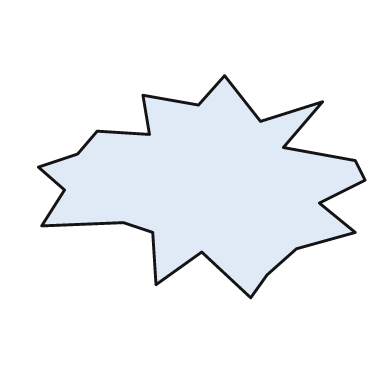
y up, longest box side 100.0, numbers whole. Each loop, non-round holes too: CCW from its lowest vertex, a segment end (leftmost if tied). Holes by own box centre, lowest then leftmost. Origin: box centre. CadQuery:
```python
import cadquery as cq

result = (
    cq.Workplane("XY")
    .moveTo(15.0, -34.0)
    .lineTo(20.0, -27.0)
    .lineTo(29.0, -19.0)
    .lineTo(47.0, -14.0)
    .lineTo(36.0, -5.0)
    .lineTo(50.0, 2.0)
    .lineTo(47.0, 8.0)
    .lineTo(25.0, 12.0)
    .lineTo(37.0, 26.0)
    .lineTo(18.0, 20.0)
    .lineTo(7.0, 34.0)
    .lineTo(-1.0, 25.0)
    .lineTo(-18.0, 28.0)
    .lineTo(-16.0, 16.0)
    .lineTo(-32.0, 17.0)
    .lineTo(-38.0, 10.0)
    .lineTo(-50.0, 6.0)
    .lineTo(-42.0, -1.0)
    .lineTo(-49.0, -12.0)
    .lineTo(-24.0, -11.0)
    .lineTo(-15.0, -14.0)
    .lineTo(-14.0, -30.0)
    .lineTo(0.0, -20.0)
    .close()
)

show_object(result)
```